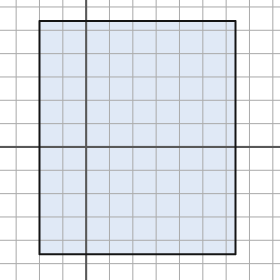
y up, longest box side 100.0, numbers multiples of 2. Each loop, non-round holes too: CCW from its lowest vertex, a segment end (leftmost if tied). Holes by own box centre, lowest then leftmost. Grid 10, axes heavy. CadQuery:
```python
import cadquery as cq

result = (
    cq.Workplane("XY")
    .moveTo(-20.0, -46.0)
    .lineTo(64.0, -46.0)
    .lineTo(64.0, 54.0)
    .lineTo(-20.0, 54.0)
    .close()
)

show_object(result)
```